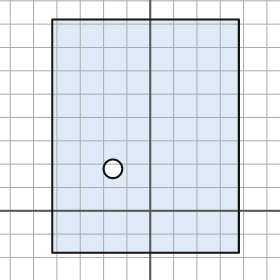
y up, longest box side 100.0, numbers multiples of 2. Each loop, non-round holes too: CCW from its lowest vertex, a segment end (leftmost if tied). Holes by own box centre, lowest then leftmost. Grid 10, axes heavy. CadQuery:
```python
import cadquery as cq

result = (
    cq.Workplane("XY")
    .moveTo(-42.0, -18.0)
    .lineTo(38.0, -18.0)
    .lineTo(38.0, 82.0)
    .lineTo(-42.0, 82.0)
    .close()
    .moveTo(-16.0, 18.0)
    .circle(4.0)
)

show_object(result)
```